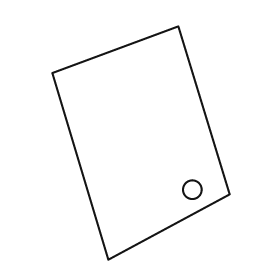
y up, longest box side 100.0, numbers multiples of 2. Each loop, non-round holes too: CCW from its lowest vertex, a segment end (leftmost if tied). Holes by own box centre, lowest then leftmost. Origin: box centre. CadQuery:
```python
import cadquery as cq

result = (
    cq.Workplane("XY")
    .moveTo(-14.0, -50.0)
    .lineTo(38.0, -22.0)
    .lineTo(16.0, 50.0)
    .lineTo(-38.0, 30.0)
    .close()
    .moveTo(22.0, -20.0)
    .circle(4.0)
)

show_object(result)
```